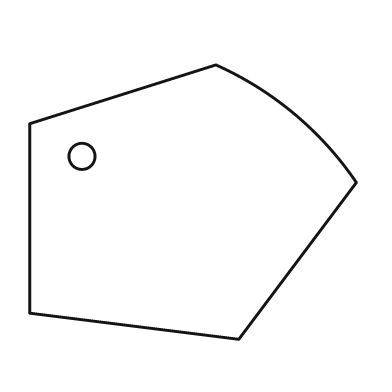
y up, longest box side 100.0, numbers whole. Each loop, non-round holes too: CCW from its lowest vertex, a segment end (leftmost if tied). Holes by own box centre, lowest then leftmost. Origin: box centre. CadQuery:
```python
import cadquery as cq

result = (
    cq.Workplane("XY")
    .moveTo(14.0, -42.0)
    .lineTo(50.0, 6.0)
    .threePointArc((31.0, 27.0), (7.0, 42.0))
    .lineTo(-50.0, 24.0)
    .lineTo(-50.0, -34.0)
    .close()
    .moveTo(-34.0, 14.0)
    .circle(4.0)
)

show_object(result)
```